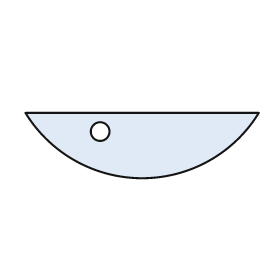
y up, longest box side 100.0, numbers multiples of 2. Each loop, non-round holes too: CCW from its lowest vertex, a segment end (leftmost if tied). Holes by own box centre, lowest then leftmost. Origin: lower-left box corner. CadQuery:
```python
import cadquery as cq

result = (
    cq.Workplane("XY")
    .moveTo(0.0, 28.0)
    .threePointArc((50.0, 0.0), (100.0, 28.0))
    .close()
    .moveTo(32.0, 20.0)
    .circle(4.0)
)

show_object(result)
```